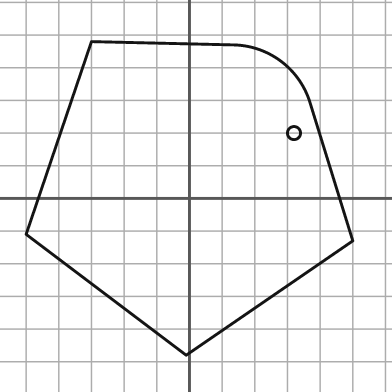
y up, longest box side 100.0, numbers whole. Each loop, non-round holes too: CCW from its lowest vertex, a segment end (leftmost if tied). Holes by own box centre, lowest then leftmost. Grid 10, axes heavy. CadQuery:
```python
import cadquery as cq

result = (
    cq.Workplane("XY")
    .moveTo(-1.0, -48.0)
    .lineTo(50.0, -13.0)
    .lineTo(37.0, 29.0)
    .threePointArc((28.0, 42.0), (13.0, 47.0))
    .lineTo(-30.0, 48.0)
    .lineTo(-50.0, -11.0)
    .close()
    .moveTo(32.0, 20.0)
    .circle(2.0)
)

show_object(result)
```